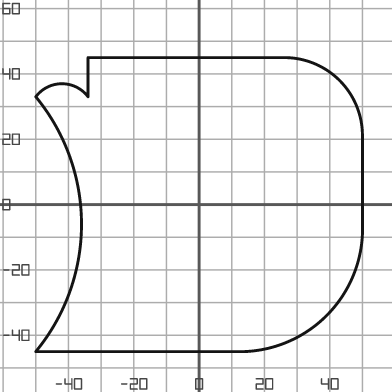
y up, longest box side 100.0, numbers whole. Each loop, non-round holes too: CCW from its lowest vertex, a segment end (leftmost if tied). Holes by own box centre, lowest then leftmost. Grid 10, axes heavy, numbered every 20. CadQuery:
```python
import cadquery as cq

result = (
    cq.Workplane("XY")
    .moveTo(-50.0, -45.0)
    .lineTo(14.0, -45.0)
    .threePointArc((39.0, -34.0), (50.0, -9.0))
    .lineTo(50.0, 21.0)
    .threePointArc((43.0, 38.0), (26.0, 45.0))
    .lineTo(-34.0, 45.0)
    .lineTo(-34.0, 33.0)
    .threePointArc((-42.0, 37.0), (-50.0, 33.0))
    .threePointArc((-36.0, -6.0), (-50.0, -45.0))
    .close()
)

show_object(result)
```